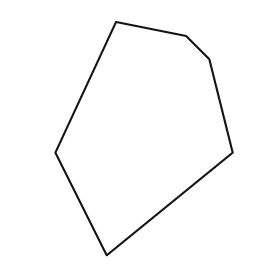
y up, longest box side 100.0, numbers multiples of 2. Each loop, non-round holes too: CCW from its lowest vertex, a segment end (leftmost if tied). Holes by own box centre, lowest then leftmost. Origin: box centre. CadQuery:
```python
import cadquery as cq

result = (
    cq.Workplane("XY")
    .moveTo(-16.0, -50.0)
    .lineTo(38.0, -6.0)
    .lineTo(28.0, 34.0)
    .lineTo(18.0, 44.0)
    .lineTo(-12.0, 50.0)
    .lineTo(-38.0, -6.0)
    .close()
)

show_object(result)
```